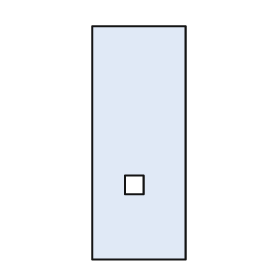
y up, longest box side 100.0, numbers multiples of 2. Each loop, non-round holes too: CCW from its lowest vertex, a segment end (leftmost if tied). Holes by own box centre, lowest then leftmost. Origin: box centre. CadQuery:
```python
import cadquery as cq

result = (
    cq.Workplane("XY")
    .moveTo(-20.0, -50.0)
    .lineTo(20.0, -50.0)
    .lineTo(20.0, 50.0)
    .lineTo(-20.0, 50.0)
    .close()
    .moveTo(-6.0, -22.0)
    .lineTo(2.0, -22.0)
    .lineTo(2.0, -14.0)
    .lineTo(-6.0, -14.0)
    .close()
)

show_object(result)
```